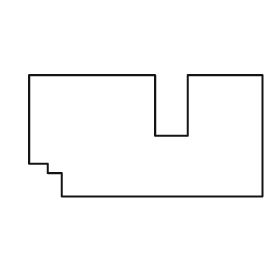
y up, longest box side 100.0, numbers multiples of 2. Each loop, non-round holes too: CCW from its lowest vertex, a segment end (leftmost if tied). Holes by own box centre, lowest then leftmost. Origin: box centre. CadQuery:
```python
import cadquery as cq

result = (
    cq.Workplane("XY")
    .moveTo(-36.0, -26.0)
    .lineTo(50.0, -26.0)
    .lineTo(50.0, 26.0)
    .lineTo(18.0, 26.0)
    .lineTo(18.0, 0.0)
    .lineTo(4.0, 0.0)
    .lineTo(4.0, 26.0)
    .lineTo(-50.0, 26.0)
    .lineTo(-50.0, -12.0)
    .lineTo(-42.0, -12.0)
    .lineTo(-42.0, -16.0)
    .lineTo(-36.0, -16.0)
    .close()
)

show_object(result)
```